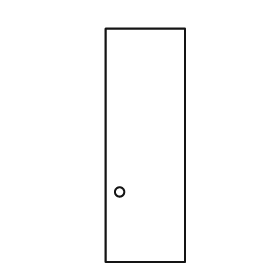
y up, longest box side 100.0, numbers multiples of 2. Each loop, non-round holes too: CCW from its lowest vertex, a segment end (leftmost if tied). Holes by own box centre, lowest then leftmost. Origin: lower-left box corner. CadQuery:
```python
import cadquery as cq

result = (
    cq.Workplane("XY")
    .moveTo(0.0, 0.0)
    .lineTo(34.0, 0.0)
    .lineTo(34.0, 100.0)
    .lineTo(0.0, 100.0)
    .close()
    .moveTo(6.0, 30.0)
    .circle(2.0)
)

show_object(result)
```